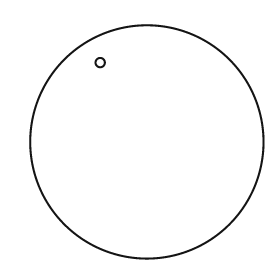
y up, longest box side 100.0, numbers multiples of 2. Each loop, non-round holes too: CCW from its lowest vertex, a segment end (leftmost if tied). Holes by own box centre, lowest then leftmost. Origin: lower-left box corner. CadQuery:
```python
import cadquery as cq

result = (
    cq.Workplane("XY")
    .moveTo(50.0, 50.0)
    .circle(50.0)
    .moveTo(30.0, 84.0)
    .circle(2.0)
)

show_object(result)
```